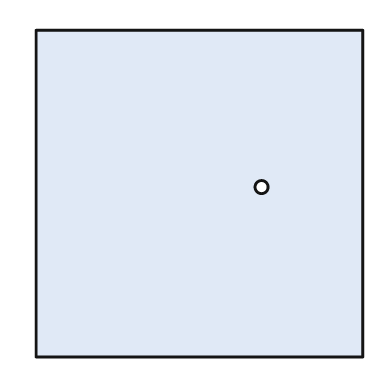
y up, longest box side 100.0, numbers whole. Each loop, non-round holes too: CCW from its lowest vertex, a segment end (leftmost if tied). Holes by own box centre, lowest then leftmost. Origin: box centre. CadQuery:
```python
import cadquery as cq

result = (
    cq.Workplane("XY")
    .moveTo(-50.0, -50.0)
    .lineTo(50.0, -50.0)
    .lineTo(50.0, 50.0)
    .lineTo(-50.0, 50.0)
    .close()
    .moveTo(19.0, 2.0)
    .circle(2.0)
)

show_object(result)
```